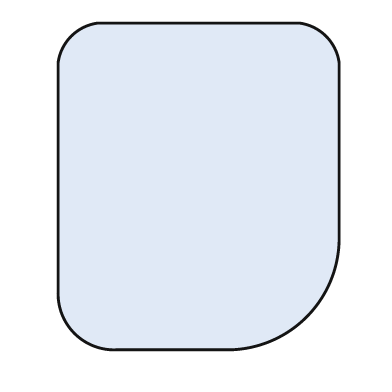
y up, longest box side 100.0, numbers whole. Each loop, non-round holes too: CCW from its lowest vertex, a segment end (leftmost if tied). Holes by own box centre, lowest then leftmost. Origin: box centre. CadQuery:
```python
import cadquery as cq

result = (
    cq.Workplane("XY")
    .moveTo(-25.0, -50.0)
    .lineTo(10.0, -50.0)
    .threePointArc((33.0, -40.0), (43.0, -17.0))
    .lineTo(43.0, 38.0)
    .threePointArc((39.0, 46.0), (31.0, 50.0))
    .lineTo(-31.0, 50.0)
    .threePointArc((-39.0, 46.0), (-43.0, 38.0))
    .lineTo(-43.0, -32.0)
    .threePointArc((-38.0, -45.0), (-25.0, -50.0))
    .close()
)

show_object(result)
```